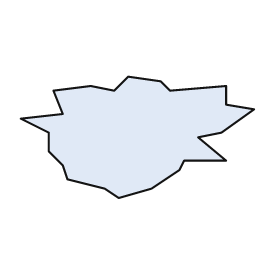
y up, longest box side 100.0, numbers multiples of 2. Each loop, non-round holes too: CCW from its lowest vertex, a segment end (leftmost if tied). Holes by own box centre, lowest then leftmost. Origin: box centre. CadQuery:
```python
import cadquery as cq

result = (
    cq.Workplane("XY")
    .moveTo(-8.0, -26.0)
    .lineTo(6.0, -22.0)
    .lineTo(18.0, -14.0)
    .lineTo(20.0, -10.0)
    .lineTo(38.0, -10.0)
    .lineTo(26.0, 0.0)
    .lineTo(36.0, 2.0)
    .lineTo(50.0, 12.0)
    .lineTo(38.0, 14.0)
    .lineTo(38.0, 22.0)
    .lineTo(14.0, 20.0)
    .lineTo(10.0, 24.0)
    .lineTo(-4.0, 26.0)
    .lineTo(-10.0, 20.0)
    .lineTo(-20.0, 22.0)
    .lineTo(-36.0, 20.0)
    .lineTo(-32.0, 10.0)
    .lineTo(-50.0, 8.0)
    .lineTo(-38.0, 2.0)
    .lineTo(-38.0, -6.0)
    .lineTo(-32.0, -12.0)
    .lineTo(-30.0, -18.0)
    .lineTo(-14.0, -22.0)
    .close()
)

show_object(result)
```